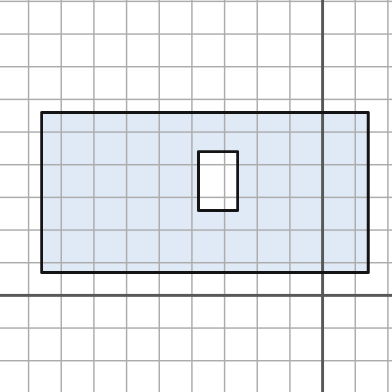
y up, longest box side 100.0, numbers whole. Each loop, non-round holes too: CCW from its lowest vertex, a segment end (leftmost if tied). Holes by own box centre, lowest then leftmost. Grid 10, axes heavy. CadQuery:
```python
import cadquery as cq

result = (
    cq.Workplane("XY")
    .moveTo(-86.0, 7.0)
    .lineTo(14.0, 7.0)
    .lineTo(14.0, 56.0)
    .lineTo(-86.0, 56.0)
    .close()
    .moveTo(-38.0, 26.0)
    .lineTo(-26.0, 26.0)
    .lineTo(-26.0, 44.0)
    .lineTo(-38.0, 44.0)
    .close()
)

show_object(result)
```